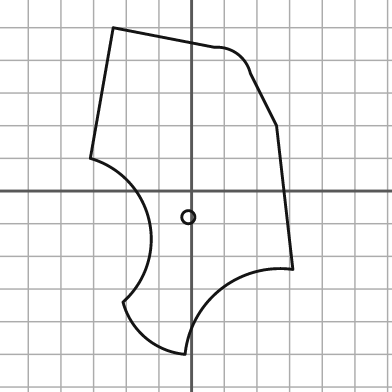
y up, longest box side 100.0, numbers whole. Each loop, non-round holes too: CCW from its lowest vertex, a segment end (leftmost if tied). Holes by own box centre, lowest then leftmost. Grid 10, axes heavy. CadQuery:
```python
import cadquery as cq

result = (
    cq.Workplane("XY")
    .moveTo(-2.0, -50.0)
    .threePointArc((9.0, -30.0), (31.0, -24.0))
    .lineTo(26.0, 20.0)
    .lineTo(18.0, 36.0)
    .threePointArc((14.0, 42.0), (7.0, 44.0))
    .lineTo(-24.0, 50.0)
    .lineTo(-31.0, 10.0)
    .threePointArc((-13.0, -9.0), (-21.0, -34.0))
    .threePointArc((-14.0, -45.0), (-2.0, -50.0))
    .close()
    .moveTo(-1.0, -8.0)
    .circle(2.0)
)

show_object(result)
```